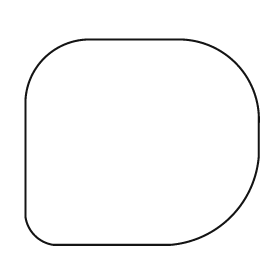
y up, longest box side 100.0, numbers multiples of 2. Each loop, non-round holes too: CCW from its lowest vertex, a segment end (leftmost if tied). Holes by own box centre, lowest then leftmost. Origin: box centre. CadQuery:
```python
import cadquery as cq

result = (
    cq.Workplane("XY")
    .moveTo(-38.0, -44.0)
    .lineTo(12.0, -44.0)
    .threePointArc((38.0, -32.0), (50.0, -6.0))
    .lineTo(50.0, 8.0)
    .threePointArc((40.0, 34.0), (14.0, 44.0))
    .lineTo(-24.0, 44.0)
    .threePointArc((-42.0, 36.0), (-50.0, 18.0))
    .lineTo(-50.0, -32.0)
    .threePointArc((-46.0, -40.0), (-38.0, -44.0))
    .close()
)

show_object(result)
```